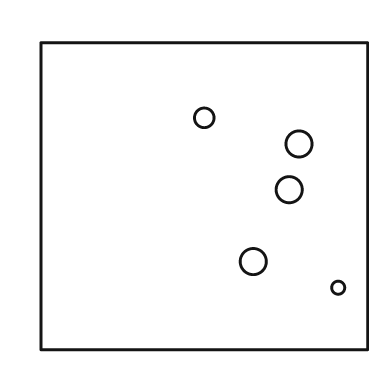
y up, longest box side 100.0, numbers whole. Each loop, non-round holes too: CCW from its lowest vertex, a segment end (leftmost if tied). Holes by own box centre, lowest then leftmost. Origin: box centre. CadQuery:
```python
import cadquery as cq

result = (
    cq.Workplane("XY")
    .moveTo(-50.0, -47.0)
    .lineTo(50.0, -47.0)
    .lineTo(50.0, 47.0)
    .lineTo(-50.0, 47.0)
    .close()
    .moveTo(41.0, -28.0)
    .circle(2.0)
    .moveTo(15.0, -20.0)
    .circle(4.0)
    .moveTo(26.0, 2.0)
    .circle(4.0)
    .moveTo(29.0, 16.0)
    .circle(4.0)
    .moveTo(0.0, 24.0)
    .circle(3.0)
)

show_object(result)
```